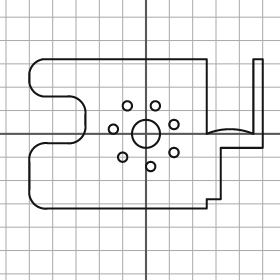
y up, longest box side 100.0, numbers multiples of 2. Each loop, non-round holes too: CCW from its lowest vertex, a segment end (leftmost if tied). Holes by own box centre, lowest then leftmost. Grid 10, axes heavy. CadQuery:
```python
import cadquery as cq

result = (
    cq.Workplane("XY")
    .moveTo(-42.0, -32.0)
    .lineTo(26.0, -32.0)
    .lineTo(26.0, -28.0)
    .lineTo(32.0, -28.0)
    .lineTo(32.0, -6.0)
    .lineTo(50.0, -6.0)
    .lineTo(50.0, 32.0)
    .lineTo(46.0, 32.0)
    .lineTo(46.0, 0.0)
    .threePointArc((36.0, 2.0), (26.0, 0.0))
    .lineTo(26.0, 32.0)
    .lineTo(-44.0, 32.0)
    .threePointArc((-48.0, 30.0), (-50.0, 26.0))
    .lineTo(-50.0, 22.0)
    .threePointArc((-48.0, 18.0), (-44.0, 16.0))
    .lineTo(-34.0, 16.0)
    .threePointArc((-28.0, 14.0), (-26.0, 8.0))
    .lineTo(-26.0, 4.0)
    .threePointArc((-28.0, -2.0), (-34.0, -4.0))
    .lineTo(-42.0, -4.0)
    .threePointArc((-48.0, -6.0), (-50.0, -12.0))
    .lineTo(-50.0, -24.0)
    .threePointArc((-48.0, -30.0), (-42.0, -32.0))
    .close()
    .moveTo(2.0, -14.0)
    .circle(2.0)
    .moveTo(-10.0, -10.0)
    .circle(2.0)
    .moveTo(12.0, -8.0)
    .circle(2.0)
    .moveTo(0.0, 0.0)
    .circle(6.0)
    .moveTo(-14.0, 2.0)
    .circle(2.0)
    .moveTo(12.0, 4.0)
    .circle(2.0)
    .moveTo(-8.0, 12.0)
    .circle(2.0)
    .moveTo(4.0, 12.0)
    .circle(2.0)
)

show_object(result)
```